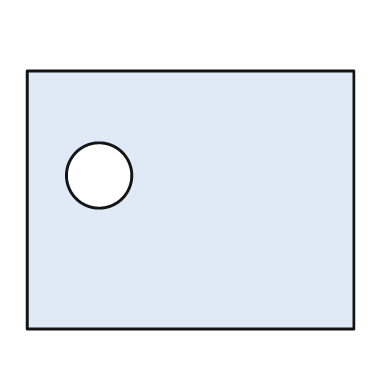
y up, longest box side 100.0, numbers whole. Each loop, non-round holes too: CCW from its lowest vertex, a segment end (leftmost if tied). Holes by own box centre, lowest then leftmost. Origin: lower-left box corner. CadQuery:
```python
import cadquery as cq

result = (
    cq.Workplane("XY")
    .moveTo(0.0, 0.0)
    .lineTo(100.0, 0.0)
    .lineTo(100.0, 79.0)
    .lineTo(0.0, 79.0)
    .close()
    .moveTo(22.0, 47.0)
    .circle(10.0)
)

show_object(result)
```